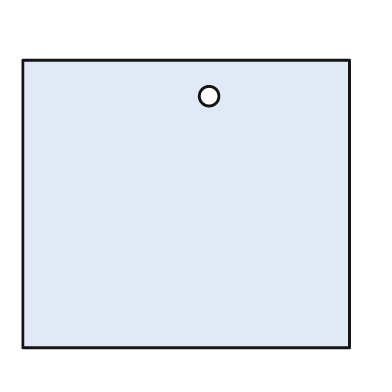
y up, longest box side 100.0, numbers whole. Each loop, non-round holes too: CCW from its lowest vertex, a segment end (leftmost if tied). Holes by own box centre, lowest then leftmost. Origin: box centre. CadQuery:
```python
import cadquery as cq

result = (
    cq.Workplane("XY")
    .moveTo(-50.0, -44.0)
    .lineTo(50.0, -44.0)
    .lineTo(50.0, 44.0)
    .lineTo(-50.0, 44.0)
    .close()
    .moveTo(7.0, 33.0)
    .circle(3.0)
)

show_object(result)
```